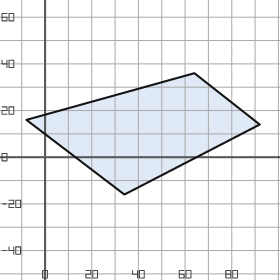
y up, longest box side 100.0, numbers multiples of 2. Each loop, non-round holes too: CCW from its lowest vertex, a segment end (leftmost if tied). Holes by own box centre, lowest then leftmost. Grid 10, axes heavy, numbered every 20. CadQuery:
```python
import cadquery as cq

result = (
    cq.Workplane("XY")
    .moveTo(34.0, -16.0)
    .lineTo(92.0, 14.0)
    .lineTo(64.0, 36.0)
    .lineTo(-8.0, 16.0)
    .close()
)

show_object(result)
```